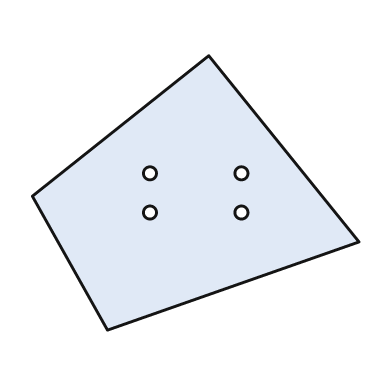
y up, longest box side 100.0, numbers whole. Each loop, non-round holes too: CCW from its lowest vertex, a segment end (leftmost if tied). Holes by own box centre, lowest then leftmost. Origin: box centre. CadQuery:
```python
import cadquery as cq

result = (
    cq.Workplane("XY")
    .moveTo(-27.0, -42.0)
    .lineTo(50.0, -15.0)
    .lineTo(4.0, 42.0)
    .lineTo(-50.0, -1.0)
    .close()
    .moveTo(-14.0, -6.0)
    .circle(2.0)
    .moveTo(14.0, -6.0)
    .circle(2.0)
    .moveTo(-14.0, 6.0)
    .circle(2.0)
    .moveTo(14.0, 6.0)
    .circle(2.0)
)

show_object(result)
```